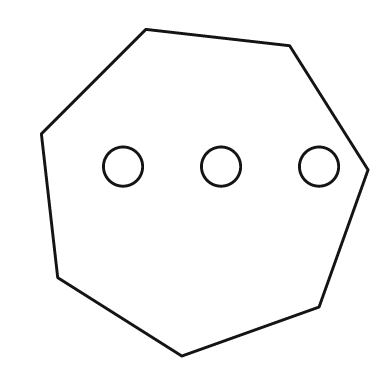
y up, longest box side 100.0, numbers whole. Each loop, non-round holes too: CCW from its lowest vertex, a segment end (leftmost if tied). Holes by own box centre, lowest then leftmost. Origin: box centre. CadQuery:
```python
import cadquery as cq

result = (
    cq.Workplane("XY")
    .moveTo(-7.0, -50.0)
    .lineTo(35.0, -35.0)
    .lineTo(50.0, 7.0)
    .lineTo(26.0, 45.0)
    .lineTo(-18.0, 50.0)
    .lineTo(-50.0, 18.0)
    .lineTo(-45.0, -26.0)
    .close()
    .moveTo(-25.0, 8.0)
    .circle(6.0)
    .moveTo(5.0, 8.0)
    .circle(6.0)
    .moveTo(35.0, 8.0)
    .circle(6.0)
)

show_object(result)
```